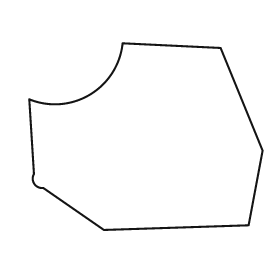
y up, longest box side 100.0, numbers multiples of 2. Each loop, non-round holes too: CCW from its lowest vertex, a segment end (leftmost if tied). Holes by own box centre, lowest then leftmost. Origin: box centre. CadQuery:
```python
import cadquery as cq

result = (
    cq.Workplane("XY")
    .moveTo(-18.0, -40.0)
    .lineTo(44.0, -38.0)
    .lineTo(50.0, -6.0)
    .lineTo(32.0, 38.0)
    .lineTo(-10.0, 40.0)
    .threePointArc((-24.0, 18.0), (-50.0, 16.0))
    .lineTo(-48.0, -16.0)
    .threePointArc((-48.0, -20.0), (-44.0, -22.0))
    .close()
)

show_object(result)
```